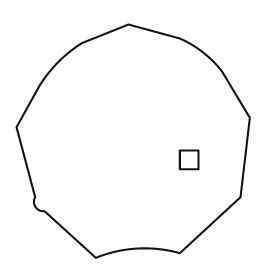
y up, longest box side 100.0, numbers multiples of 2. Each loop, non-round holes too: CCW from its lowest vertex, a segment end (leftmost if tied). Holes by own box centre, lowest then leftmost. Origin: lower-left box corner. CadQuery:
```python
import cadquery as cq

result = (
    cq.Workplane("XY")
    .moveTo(34.0, 0.0)
    .threePointArc((52.0, 4.0), (70.0, 2.0))
    .lineTo(96.0, 26.0)
    .lineTo(100.0, 60.0)
    .lineTo(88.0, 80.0)
    .threePointArc((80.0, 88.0), (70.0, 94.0))
    .lineTo(48.0, 100.0)
    .lineTo(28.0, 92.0)
    .threePointArc((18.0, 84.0), (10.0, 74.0))
    .lineTo(0.0, 56.0)
    .lineTo(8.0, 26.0)
    .threePointArc((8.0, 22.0), (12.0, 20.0))
    .close()
    .moveTo(70.0, 38.0)
    .lineTo(78.0, 38.0)
    .lineTo(78.0, 46.0)
    .lineTo(70.0, 46.0)
    .close()
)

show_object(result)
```